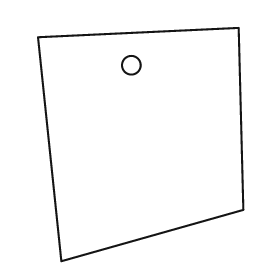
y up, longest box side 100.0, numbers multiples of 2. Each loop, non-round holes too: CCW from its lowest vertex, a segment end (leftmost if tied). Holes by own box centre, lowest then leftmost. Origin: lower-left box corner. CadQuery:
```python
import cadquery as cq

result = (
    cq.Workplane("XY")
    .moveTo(10.0, 0.0)
    .lineTo(88.0, 22.0)
    .lineTo(86.0, 100.0)
    .lineTo(0.0, 96.0)
    .close()
    .moveTo(40.0, 84.0)
    .circle(4.0)
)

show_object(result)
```